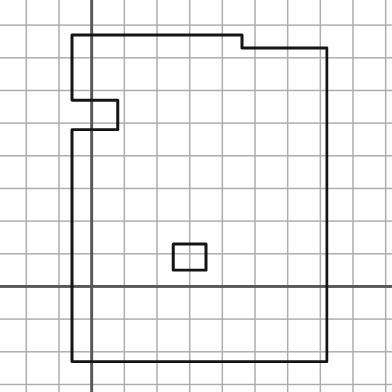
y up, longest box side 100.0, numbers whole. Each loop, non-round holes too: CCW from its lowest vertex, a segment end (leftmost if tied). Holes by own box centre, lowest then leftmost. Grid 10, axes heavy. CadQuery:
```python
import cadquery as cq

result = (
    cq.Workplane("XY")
    .moveTo(-6.0, -23.0)
    .lineTo(72.0, -23.0)
    .lineTo(72.0, 73.0)
    .lineTo(46.0, 73.0)
    .lineTo(46.0, 77.0)
    .lineTo(-6.0, 77.0)
    .lineTo(-6.0, 57.0)
    .lineTo(8.0, 57.0)
    .lineTo(8.0, 48.0)
    .lineTo(-6.0, 48.0)
    .close()
    .moveTo(25.0, 5.0)
    .lineTo(35.0, 5.0)
    .lineTo(35.0, 13.0)
    .lineTo(25.0, 13.0)
    .close()
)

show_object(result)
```